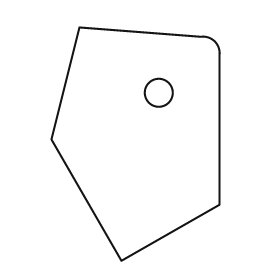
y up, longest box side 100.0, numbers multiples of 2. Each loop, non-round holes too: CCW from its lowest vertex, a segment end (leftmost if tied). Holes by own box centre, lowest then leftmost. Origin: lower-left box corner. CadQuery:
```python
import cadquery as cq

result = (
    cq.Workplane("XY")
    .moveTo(30.0, 0.0)
    .lineTo(72.0, 24.0)
    .lineTo(72.0, 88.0)
    .threePointArc((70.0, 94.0), (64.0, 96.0))
    .lineTo(12.0, 100.0)
    .lineTo(0.0, 52.0)
    .close()
    .moveTo(46.0, 72.0)
    .circle(6.0)
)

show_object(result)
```